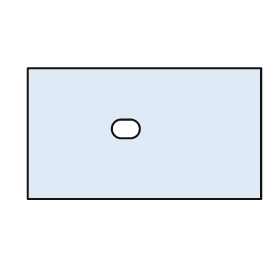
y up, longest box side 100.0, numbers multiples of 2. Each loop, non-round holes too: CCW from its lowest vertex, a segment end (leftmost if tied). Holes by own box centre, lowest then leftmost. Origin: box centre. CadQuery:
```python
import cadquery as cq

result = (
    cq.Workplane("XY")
    .moveTo(-50.0, -28.0)
    .lineTo(50.0, -28.0)
    .lineTo(50.0, 28.0)
    .lineTo(-50.0, 28.0)
    .close()
    .moveTo(-10.0, -2.0)
    .lineTo(-6.0, -2.0)
    .threePointArc((-2.0, 2.0), (-6.0, 6.0))
    .lineTo(-10.0, 6.0)
    .threePointArc((-14.0, 2.0), (-10.0, -2.0))
    .close()
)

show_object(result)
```